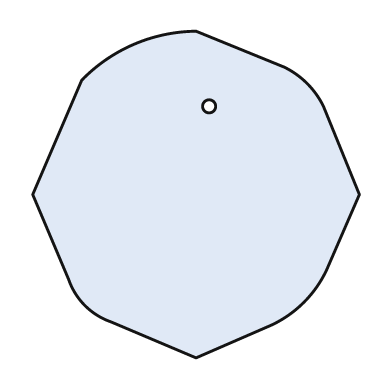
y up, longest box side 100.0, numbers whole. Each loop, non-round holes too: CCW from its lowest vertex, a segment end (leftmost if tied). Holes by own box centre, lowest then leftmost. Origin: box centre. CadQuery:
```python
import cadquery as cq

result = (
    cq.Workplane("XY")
    .moveTo(0.0, -50.0)
    .lineTo(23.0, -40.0)
    .threePointArc((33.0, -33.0), (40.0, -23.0))
    .lineTo(50.0, 0.0)
    .lineTo(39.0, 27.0)
    .threePointArc((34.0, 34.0), (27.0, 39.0))
    .lineTo(0.0, 50.0)
    .threePointArc((-19.0, 46.0), (-35.0, 35.0))
    .lineTo(-50.0, 0.0)
    .lineTo(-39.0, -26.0)
    .threePointArc((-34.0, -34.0), (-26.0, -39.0))
    .close()
    .moveTo(4.0, 27.0)
    .circle(2.0)
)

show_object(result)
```